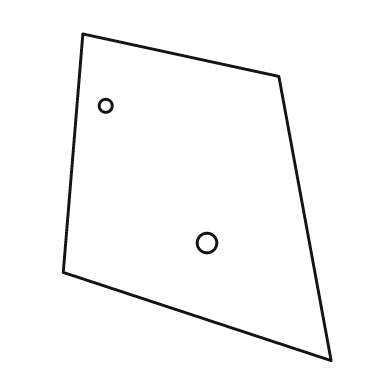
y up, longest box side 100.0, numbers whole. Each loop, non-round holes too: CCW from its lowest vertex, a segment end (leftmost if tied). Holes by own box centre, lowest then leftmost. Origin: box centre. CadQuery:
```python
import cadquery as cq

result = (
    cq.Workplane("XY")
    .moveTo(41.0, -50.0)
    .lineTo(25.0, 37.0)
    .lineTo(-35.0, 50.0)
    .lineTo(-41.0, -23.0)
    .close()
    .moveTo(3.0, -14.0)
    .circle(3.0)
    .moveTo(-28.0, 28.0)
    .circle(2.0)
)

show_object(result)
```